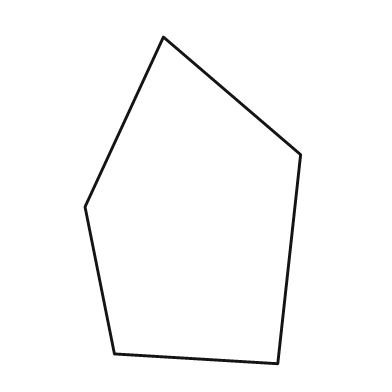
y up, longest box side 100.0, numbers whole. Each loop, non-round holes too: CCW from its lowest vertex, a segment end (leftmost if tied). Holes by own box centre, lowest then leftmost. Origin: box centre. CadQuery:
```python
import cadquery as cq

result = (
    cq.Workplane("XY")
    .moveTo(26.0, -50.0)
    .lineTo(33.0, 14.0)
    .lineTo(-9.0, 50.0)
    .lineTo(-33.0, -2.0)
    .lineTo(-24.0, -47.0)
    .close()
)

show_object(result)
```